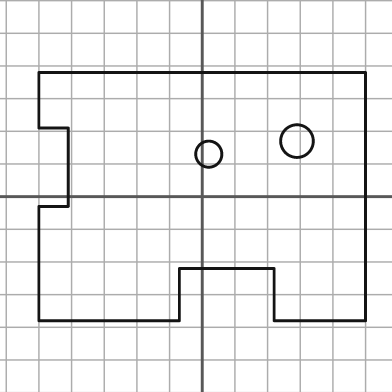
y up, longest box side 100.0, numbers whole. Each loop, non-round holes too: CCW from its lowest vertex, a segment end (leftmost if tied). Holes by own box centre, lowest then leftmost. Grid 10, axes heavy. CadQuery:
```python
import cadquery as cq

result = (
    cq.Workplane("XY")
    .moveTo(-50.0, -38.0)
    .lineTo(-7.0, -38.0)
    .lineTo(-7.0, -22.0)
    .lineTo(22.0, -22.0)
    .lineTo(22.0, -38.0)
    .lineTo(50.0, -38.0)
    .lineTo(50.0, 38.0)
    .lineTo(-50.0, 38.0)
    .lineTo(-50.0, 21.0)
    .lineTo(-41.0, 21.0)
    .lineTo(-41.0, -3.0)
    .lineTo(-50.0, -3.0)
    .close()
    .moveTo(2.0, 13.0)
    .circle(4.0)
    .moveTo(29.0, 17.0)
    .circle(5.0)
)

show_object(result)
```